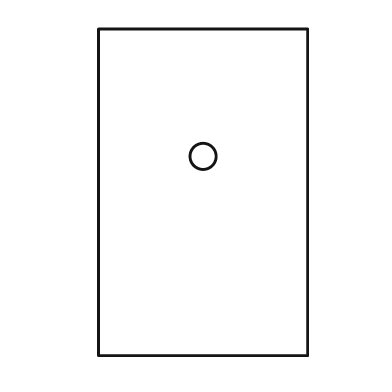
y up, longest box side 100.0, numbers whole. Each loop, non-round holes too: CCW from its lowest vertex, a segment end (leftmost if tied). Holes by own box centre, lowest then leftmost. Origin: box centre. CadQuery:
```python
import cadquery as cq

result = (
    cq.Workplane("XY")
    .moveTo(-32.0, -50.0)
    .lineTo(32.0, -50.0)
    .lineTo(32.0, 50.0)
    .lineTo(-32.0, 50.0)
    .close()
    .moveTo(0.0, 11.0)
    .circle(4.0)
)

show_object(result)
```